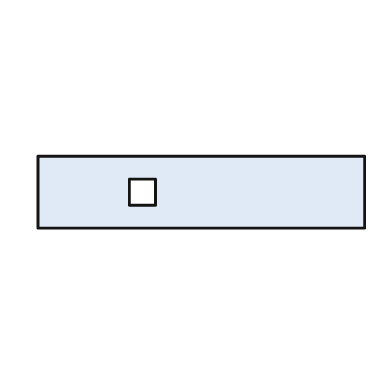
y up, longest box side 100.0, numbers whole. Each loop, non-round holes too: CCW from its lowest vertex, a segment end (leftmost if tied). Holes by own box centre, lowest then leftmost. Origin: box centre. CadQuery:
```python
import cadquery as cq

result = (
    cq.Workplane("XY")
    .moveTo(-50.0, -11.0)
    .lineTo(50.0, -11.0)
    .lineTo(50.0, 11.0)
    .lineTo(-50.0, 11.0)
    .close()
    .moveTo(-22.0, -4.0)
    .lineTo(-14.0, -4.0)
    .lineTo(-14.0, 4.0)
    .lineTo(-22.0, 4.0)
    .close()
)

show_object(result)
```